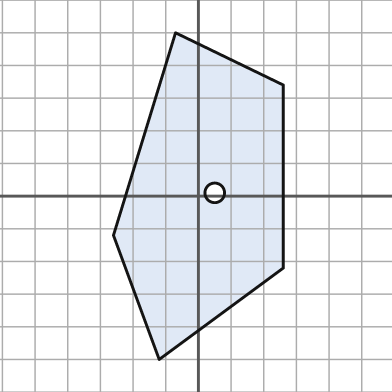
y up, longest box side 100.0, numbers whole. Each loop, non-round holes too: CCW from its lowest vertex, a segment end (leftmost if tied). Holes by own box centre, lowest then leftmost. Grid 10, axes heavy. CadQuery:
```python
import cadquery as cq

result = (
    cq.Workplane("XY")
    .moveTo(-12.0, -50.0)
    .lineTo(26.0, -22.0)
    .lineTo(26.0, 34.0)
    .lineTo(-7.0, 50.0)
    .lineTo(-26.0, -12.0)
    .close()
    .moveTo(5.0, 1.0)
    .circle(3.0)
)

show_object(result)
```